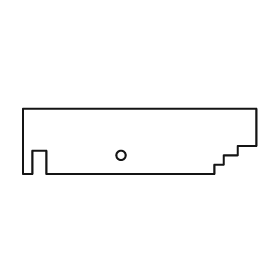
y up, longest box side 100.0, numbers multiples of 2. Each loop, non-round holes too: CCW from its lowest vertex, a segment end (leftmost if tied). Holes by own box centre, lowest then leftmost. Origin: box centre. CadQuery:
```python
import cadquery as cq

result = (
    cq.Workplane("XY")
    .moveTo(-50.0, -14.0)
    .lineTo(-46.0, -14.0)
    .lineTo(-46.0, -4.0)
    .lineTo(-40.0, -4.0)
    .lineTo(-40.0, -14.0)
    .lineTo(32.0, -14.0)
    .lineTo(32.0, -10.0)
    .lineTo(36.0, -10.0)
    .lineTo(36.0, -6.0)
    .lineTo(42.0, -6.0)
    .lineTo(42.0, -2.0)
    .lineTo(50.0, -2.0)
    .lineTo(50.0, 14.0)
    .lineTo(-50.0, 14.0)
    .close()
    .moveTo(-8.0, -6.0)
    .circle(2.0)
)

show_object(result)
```